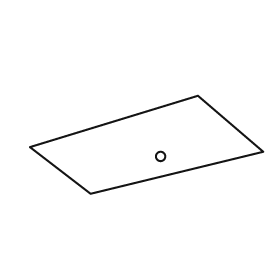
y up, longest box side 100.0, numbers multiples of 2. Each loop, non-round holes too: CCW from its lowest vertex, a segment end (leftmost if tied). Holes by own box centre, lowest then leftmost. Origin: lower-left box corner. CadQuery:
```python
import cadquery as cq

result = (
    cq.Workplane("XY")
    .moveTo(26.0, 0.0)
    .lineTo(100.0, 18.0)
    .lineTo(72.0, 42.0)
    .lineTo(0.0, 20.0)
    .close()
    .moveTo(56.0, 16.0)
    .circle(2.0)
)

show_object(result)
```